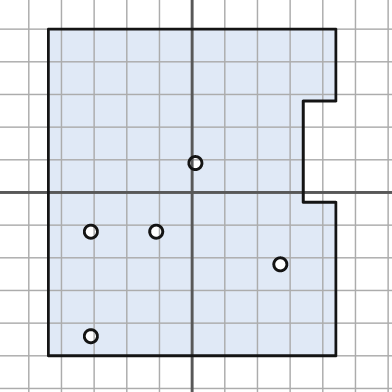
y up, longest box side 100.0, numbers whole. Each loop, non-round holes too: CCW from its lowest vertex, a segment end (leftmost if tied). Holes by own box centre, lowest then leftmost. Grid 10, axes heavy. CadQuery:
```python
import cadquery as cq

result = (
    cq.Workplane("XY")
    .moveTo(-44.0, -50.0)
    .lineTo(44.0, -50.0)
    .lineTo(44.0, -3.0)
    .lineTo(34.0, -3.0)
    .lineTo(34.0, 28.0)
    .lineTo(44.0, 28.0)
    .lineTo(44.0, 50.0)
    .lineTo(-44.0, 50.0)
    .close()
    .moveTo(-31.0, -44.0)
    .circle(2.0)
    .moveTo(27.0, -22.0)
    .circle(2.0)
    .moveTo(-31.0, -12.0)
    .circle(2.0)
    .moveTo(-11.0, -12.0)
    .circle(2.0)
    .moveTo(1.0, 9.0)
    .circle(2.0)
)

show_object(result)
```